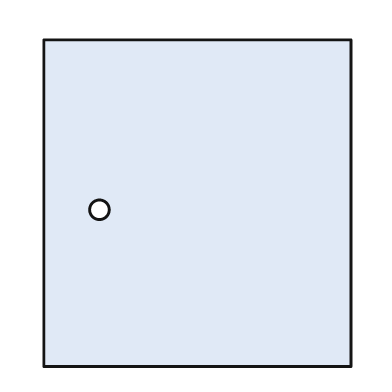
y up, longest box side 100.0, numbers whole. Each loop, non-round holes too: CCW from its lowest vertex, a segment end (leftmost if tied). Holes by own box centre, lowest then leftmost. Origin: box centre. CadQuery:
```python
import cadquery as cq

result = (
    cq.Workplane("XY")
    .moveTo(-47.0, -50.0)
    .lineTo(47.0, -50.0)
    .lineTo(47.0, 50.0)
    .lineTo(-47.0, 50.0)
    .close()
    .moveTo(-30.0, -2.0)
    .circle(3.0)
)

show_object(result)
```